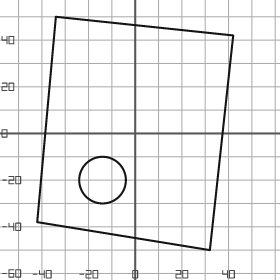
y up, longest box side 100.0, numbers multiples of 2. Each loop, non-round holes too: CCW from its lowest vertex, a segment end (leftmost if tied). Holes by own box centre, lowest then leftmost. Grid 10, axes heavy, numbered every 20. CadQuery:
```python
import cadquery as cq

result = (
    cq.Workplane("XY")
    .moveTo(32.0, -50.0)
    .lineTo(42.0, 42.0)
    .lineTo(-34.0, 50.0)
    .lineTo(-42.0, -38.0)
    .close()
    .moveTo(-14.0, -20.0)
    .circle(10.0)
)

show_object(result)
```